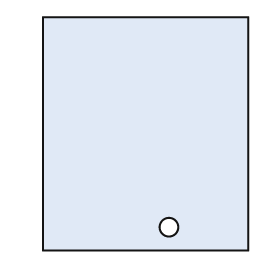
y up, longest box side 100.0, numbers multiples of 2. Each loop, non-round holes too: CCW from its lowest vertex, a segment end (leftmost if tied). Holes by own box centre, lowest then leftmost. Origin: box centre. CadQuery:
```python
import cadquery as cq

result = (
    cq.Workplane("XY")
    .moveTo(-44.0, -50.0)
    .lineTo(44.0, -50.0)
    .lineTo(44.0, 50.0)
    .lineTo(-44.0, 50.0)
    .close()
    .moveTo(10.0, -40.0)
    .circle(4.0)
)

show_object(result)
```